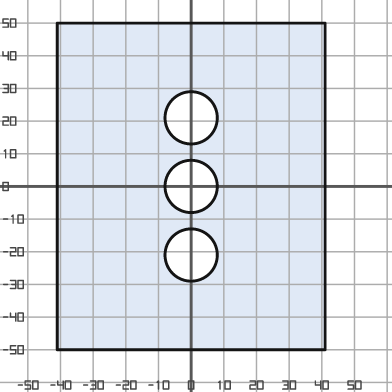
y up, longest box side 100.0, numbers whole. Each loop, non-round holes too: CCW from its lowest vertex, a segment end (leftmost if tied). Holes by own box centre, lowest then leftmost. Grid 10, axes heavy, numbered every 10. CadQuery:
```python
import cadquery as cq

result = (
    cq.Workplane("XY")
    .moveTo(-41.0, -50.0)
    .lineTo(41.0, -50.0)
    .lineTo(41.0, 50.0)
    .lineTo(-41.0, 50.0)
    .close()
    .moveTo(0.0, -21.0)
    .circle(8.0)
    .moveTo(0.0, 0.0)
    .circle(8.0)
    .moveTo(0.0, 21.0)
    .circle(8.0)
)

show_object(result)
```